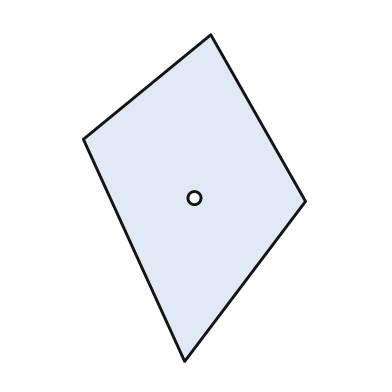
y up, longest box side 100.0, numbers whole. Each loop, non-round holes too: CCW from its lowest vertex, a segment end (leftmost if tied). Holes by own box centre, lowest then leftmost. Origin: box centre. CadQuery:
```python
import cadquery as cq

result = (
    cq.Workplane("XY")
    .moveTo(-3.0, -50.0)
    .lineTo(34.0, -1.0)
    .lineTo(5.0, 50.0)
    .lineTo(-34.0, 18.0)
    .close()
    .moveTo(0.0, 0.0)
    .circle(2.0)
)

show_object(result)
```